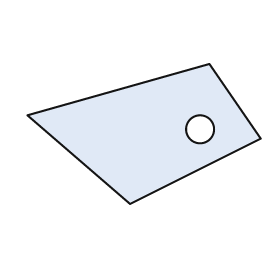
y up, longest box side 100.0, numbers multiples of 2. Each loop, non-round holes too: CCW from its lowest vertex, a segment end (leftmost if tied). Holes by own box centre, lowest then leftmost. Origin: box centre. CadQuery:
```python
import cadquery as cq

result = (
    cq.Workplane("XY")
    .moveTo(-6.0, -30.0)
    .lineTo(50.0, -2.0)
    .lineTo(28.0, 30.0)
    .lineTo(-50.0, 8.0)
    .close()
    .moveTo(24.0, 2.0)
    .circle(6.0)
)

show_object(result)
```